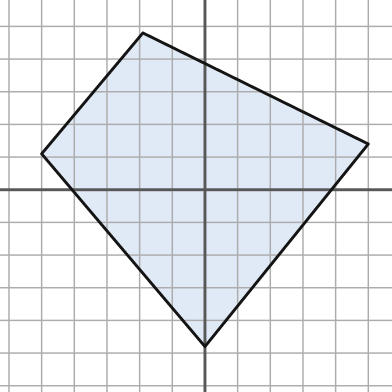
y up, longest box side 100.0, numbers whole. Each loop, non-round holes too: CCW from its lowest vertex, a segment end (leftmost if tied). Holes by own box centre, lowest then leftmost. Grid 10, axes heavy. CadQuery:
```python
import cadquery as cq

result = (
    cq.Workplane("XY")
    .moveTo(0.0, -48.0)
    .lineTo(50.0, 14.0)
    .lineTo(-19.0, 48.0)
    .lineTo(-50.0, 11.0)
    .close()
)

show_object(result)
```